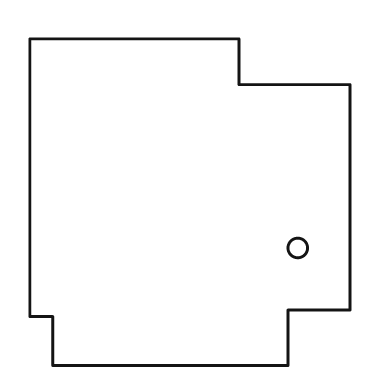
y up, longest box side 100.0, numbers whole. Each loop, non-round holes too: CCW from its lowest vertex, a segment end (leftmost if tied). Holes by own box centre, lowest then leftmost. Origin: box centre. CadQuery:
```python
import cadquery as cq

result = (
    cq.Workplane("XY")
    .moveTo(-42.0, -50.0)
    .lineTo(30.0, -50.0)
    .lineTo(30.0, -33.0)
    .lineTo(49.0, -33.0)
    .lineTo(49.0, 36.0)
    .lineTo(15.0, 36.0)
    .lineTo(15.0, 50.0)
    .lineTo(-49.0, 50.0)
    .lineTo(-49.0, -35.0)
    .lineTo(-42.0, -35.0)
    .close()
    .moveTo(33.0, -14.0)
    .circle(3.0)
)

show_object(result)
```